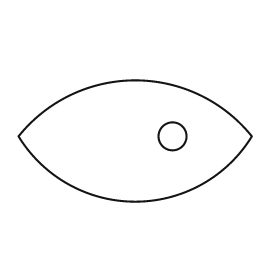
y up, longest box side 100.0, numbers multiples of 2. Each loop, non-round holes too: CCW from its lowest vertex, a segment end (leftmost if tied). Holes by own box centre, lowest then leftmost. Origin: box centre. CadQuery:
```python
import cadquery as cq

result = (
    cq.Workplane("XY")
    .moveTo(-50.0, 2.0)
    .threePointArc((0.0, -26.0), (50.0, 2.0))
    .threePointArc((0.0, 26.0), (-50.0, 2.0))
    .close()
    .moveTo(16.0, 2.0)
    .circle(6.0)
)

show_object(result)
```